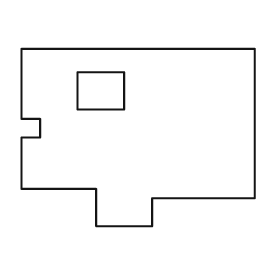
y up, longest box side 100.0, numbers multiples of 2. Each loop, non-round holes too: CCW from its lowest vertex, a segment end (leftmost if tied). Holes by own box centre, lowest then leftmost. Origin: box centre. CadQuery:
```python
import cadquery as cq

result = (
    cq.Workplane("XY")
    .moveTo(-18.0, -38.0)
    .lineTo(6.0, -38.0)
    .lineTo(6.0, -26.0)
    .lineTo(50.0, -26.0)
    .lineTo(50.0, 38.0)
    .lineTo(-50.0, 38.0)
    .lineTo(-50.0, 8.0)
    .lineTo(-42.0, 8.0)
    .lineTo(-42.0, 0.0)
    .lineTo(-50.0, 0.0)
    .lineTo(-50.0, -22.0)
    .lineTo(-18.0, -22.0)
    .close()
    .moveTo(-26.0, 12.0)
    .lineTo(-6.0, 12.0)
    .lineTo(-6.0, 28.0)
    .lineTo(-26.0, 28.0)
    .close()
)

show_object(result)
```